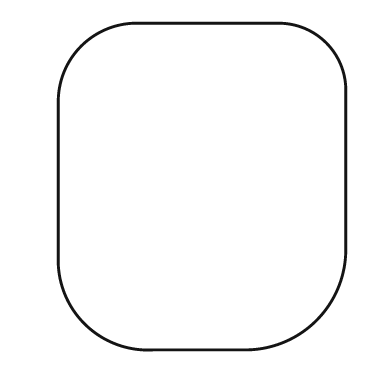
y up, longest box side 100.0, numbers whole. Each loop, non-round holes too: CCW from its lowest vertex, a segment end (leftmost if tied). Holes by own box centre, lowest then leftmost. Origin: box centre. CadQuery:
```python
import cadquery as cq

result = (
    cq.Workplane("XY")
    .moveTo(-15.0, -50.0)
    .lineTo(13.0, -50.0)
    .threePointArc((35.0, -41.0), (44.0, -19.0))
    .lineTo(44.0, 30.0)
    .threePointArc((38.0, 44.0), (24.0, 50.0))
    .lineTo(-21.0, 50.0)
    .threePointArc((-37.0, 43.0), (-44.0, 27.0))
    .lineTo(-44.0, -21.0)
    .threePointArc((-36.0, -42.0), (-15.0, -50.0))
    .close()
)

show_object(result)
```